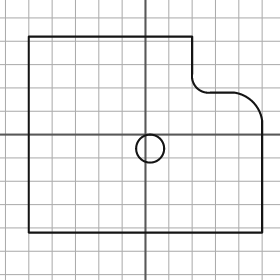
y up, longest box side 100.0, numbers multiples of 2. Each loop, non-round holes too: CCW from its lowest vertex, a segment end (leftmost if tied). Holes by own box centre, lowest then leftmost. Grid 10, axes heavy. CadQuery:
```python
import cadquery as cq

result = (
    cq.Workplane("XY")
    .moveTo(-50.0, -42.0)
    .lineTo(50.0, -42.0)
    .lineTo(50.0, 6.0)
    .threePointArc((46.0, 14.0), (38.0, 18.0))
    .lineTo(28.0, 18.0)
    .threePointArc((22.0, 20.0), (20.0, 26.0))
    .lineTo(20.0, 42.0)
    .lineTo(-50.0, 42.0)
    .close()
    .moveTo(2.0, -6.0)
    .circle(6.0)
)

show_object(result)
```